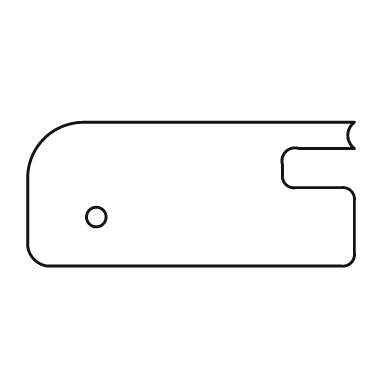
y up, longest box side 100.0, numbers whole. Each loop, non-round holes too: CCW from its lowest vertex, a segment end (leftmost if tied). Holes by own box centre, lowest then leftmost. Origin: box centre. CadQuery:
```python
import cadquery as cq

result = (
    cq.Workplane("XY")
    .moveTo(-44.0, -22.0)
    .lineTo(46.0, -22.0)
    .threePointArc((49.0, -21.0), (50.0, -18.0))
    .lineTo(50.0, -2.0)
    .threePointArc((49.0, 1.0), (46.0, 2.0))
    .lineTo(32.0, 2.0)
    .threePointArc((29.0, 3.0), (28.0, 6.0))
    .lineTo(28.0, 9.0)
    .threePointArc((29.0, 13.0), (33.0, 14.0))
    .lineTo(50.0, 14.0)
    .threePointArc((48.0, 18.0), (50.0, 22.0))
    .lineTo(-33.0, 22.0)
    .threePointArc((-45.0, 17.0), (-50.0, 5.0))
    .lineTo(-50.0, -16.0)
    .threePointArc((-48.0, -20.0), (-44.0, -22.0))
    .close()
    .moveTo(-29.0, -7.0)
    .circle(3.0)
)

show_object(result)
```